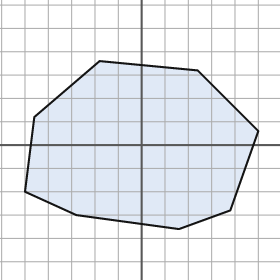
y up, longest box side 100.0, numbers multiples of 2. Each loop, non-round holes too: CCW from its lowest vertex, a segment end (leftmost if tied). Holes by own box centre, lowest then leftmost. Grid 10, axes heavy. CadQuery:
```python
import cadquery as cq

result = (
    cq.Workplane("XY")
    .moveTo(16.0, -36.0)
    .lineTo(38.0, -28.0)
    .lineTo(50.0, 6.0)
    .lineTo(24.0, 32.0)
    .lineTo(-18.0, 36.0)
    .lineTo(-46.0, 12.0)
    .lineTo(-50.0, -20.0)
    .lineTo(-28.0, -30.0)
    .close()
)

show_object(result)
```